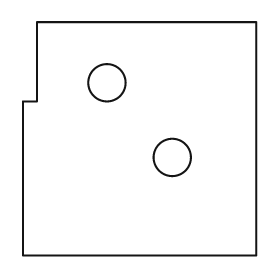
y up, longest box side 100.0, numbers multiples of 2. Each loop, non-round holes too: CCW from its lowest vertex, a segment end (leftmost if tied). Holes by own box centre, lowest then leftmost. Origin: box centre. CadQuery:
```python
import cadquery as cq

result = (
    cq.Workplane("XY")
    .moveTo(-50.0, -50.0)
    .lineTo(50.0, -50.0)
    .lineTo(50.0, 50.0)
    .lineTo(-44.0, 50.0)
    .lineTo(-44.0, 16.0)
    .lineTo(-50.0, 16.0)
    .close()
    .moveTo(14.0, -8.0)
    .circle(8.0)
    .moveTo(-14.0, 24.0)
    .circle(8.0)
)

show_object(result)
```